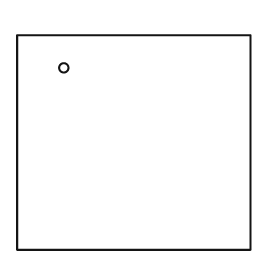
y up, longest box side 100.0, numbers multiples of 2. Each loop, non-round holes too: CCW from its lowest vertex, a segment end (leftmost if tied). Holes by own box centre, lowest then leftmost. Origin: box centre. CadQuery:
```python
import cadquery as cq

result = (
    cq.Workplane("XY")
    .moveTo(-50.0, -46.0)
    .lineTo(50.0, -46.0)
    .lineTo(50.0, 46.0)
    .lineTo(-50.0, 46.0)
    .close()
    .moveTo(-30.0, 32.0)
    .circle(2.0)
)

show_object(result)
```